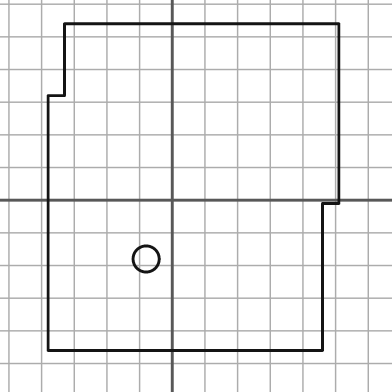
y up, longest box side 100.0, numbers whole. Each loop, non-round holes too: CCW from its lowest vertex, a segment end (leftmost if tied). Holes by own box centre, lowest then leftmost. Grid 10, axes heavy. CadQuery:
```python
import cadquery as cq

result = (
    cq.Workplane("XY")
    .moveTo(-38.0, -46.0)
    .lineTo(46.0, -46.0)
    .lineTo(46.0, -1.0)
    .lineTo(51.0, -1.0)
    .lineTo(51.0, 54.0)
    .lineTo(-33.0, 54.0)
    .lineTo(-33.0, 32.0)
    .lineTo(-38.0, 32.0)
    .close()
    .moveTo(-8.0, -18.0)
    .circle(4.0)
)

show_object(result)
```